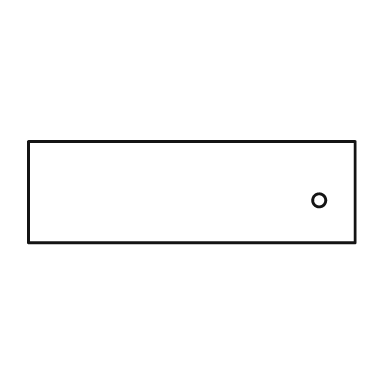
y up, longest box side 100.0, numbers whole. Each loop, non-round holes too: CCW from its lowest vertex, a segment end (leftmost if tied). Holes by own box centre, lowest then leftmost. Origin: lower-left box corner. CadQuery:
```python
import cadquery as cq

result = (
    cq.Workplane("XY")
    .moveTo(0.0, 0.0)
    .lineTo(100.0, 0.0)
    .lineTo(100.0, 31.0)
    .lineTo(0.0, 31.0)
    .close()
    .moveTo(89.0, 13.0)
    .circle(2.0)
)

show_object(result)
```